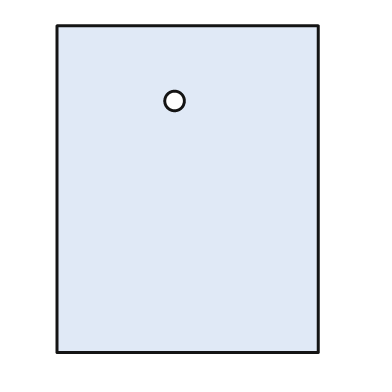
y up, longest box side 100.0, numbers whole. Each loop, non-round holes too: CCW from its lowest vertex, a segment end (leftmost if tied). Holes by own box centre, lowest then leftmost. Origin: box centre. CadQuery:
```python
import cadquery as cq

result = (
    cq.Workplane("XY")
    .moveTo(-40.0, -50.0)
    .lineTo(40.0, -50.0)
    .lineTo(40.0, 50.0)
    .lineTo(-40.0, 50.0)
    .close()
    .moveTo(-4.0, 27.0)
    .circle(3.0)
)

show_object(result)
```